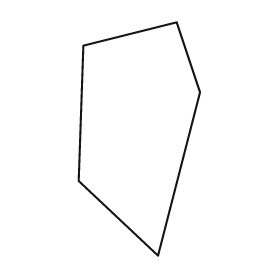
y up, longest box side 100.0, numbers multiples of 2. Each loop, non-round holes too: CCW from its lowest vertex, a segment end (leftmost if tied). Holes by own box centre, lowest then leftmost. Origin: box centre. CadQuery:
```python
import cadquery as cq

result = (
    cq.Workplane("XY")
    .moveTo(8.0, -50.0)
    .lineTo(26.0, 20.0)
    .lineTo(16.0, 50.0)
    .lineTo(-24.0, 40.0)
    .lineTo(-26.0, -18.0)
    .close()
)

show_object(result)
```